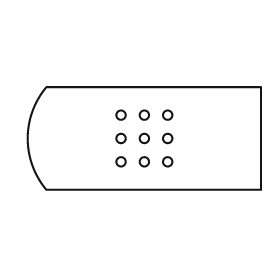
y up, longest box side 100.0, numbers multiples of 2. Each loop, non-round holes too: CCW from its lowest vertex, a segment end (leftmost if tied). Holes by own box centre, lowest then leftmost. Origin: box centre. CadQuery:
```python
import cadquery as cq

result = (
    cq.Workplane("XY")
    .moveTo(-42.0, -22.0)
    .lineTo(50.0, -22.0)
    .lineTo(50.0, 22.0)
    .lineTo(-42.0, 22.0)
    .threePointArc((-50.0, 0.0), (-42.0, -22.0))
    .close()
    .moveTo(-10.0, -10.0)
    .circle(2.0)
    .moveTo(0.0, -10.0)
    .circle(2.0)
    .moveTo(10.0, -10.0)
    .circle(2.0)
    .moveTo(-10.0, 0.0)
    .circle(2.0)
    .moveTo(0.0, 0.0)
    .circle(2.0)
    .moveTo(10.0, 0.0)
    .circle(2.0)
    .moveTo(-10.0, 10.0)
    .circle(2.0)
    .moveTo(0.0, 10.0)
    .circle(2.0)
    .moveTo(10.0, 10.0)
    .circle(2.0)
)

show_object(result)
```